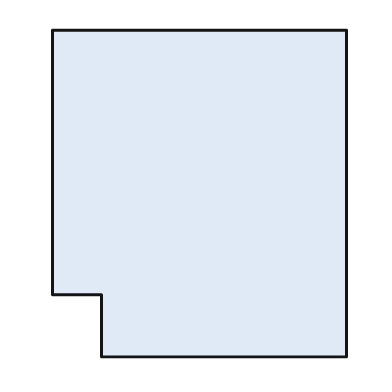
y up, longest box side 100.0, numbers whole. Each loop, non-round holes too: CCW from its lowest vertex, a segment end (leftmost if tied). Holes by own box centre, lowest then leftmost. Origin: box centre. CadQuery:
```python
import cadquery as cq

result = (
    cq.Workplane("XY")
    .moveTo(-30.0, -50.0)
    .lineTo(45.0, -50.0)
    .lineTo(45.0, 50.0)
    .lineTo(-45.0, 50.0)
    .lineTo(-45.0, -31.0)
    .lineTo(-30.0, -31.0)
    .close()
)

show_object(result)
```